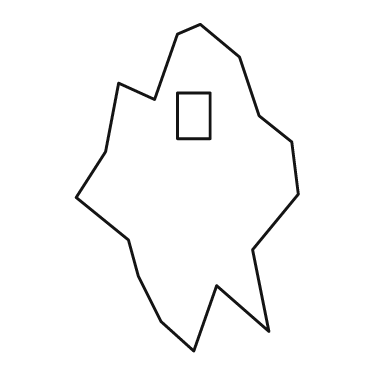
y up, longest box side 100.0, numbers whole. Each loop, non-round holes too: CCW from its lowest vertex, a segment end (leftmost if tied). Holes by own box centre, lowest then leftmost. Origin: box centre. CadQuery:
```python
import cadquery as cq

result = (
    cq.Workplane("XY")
    .moveTo(2.0, -50.0)
    .lineTo(9.0, -30.0)
    .lineTo(25.0, -44.0)
    .lineTo(20.0, -19.0)
    .lineTo(34.0, -2.0)
    .lineTo(32.0, 14.0)
    .lineTo(22.0, 22.0)
    .lineTo(16.0, 40.0)
    .lineTo(4.0, 50.0)
    .lineTo(-3.0, 47.0)
    .lineTo(-10.0, 27.0)
    .lineTo(-21.0, 32.0)
    .lineTo(-25.0, 11.0)
    .lineTo(-34.0, -3.0)
    .lineTo(-18.0, -16.0)
    .lineTo(-15.0, -27.0)
    .lineTo(-8.0, -41.0)
    .close()
    .moveTo(-3.0, 15.0)
    .lineTo(7.0, 15.0)
    .lineTo(7.0, 29.0)
    .lineTo(-3.0, 29.0)
    .close()
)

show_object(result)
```